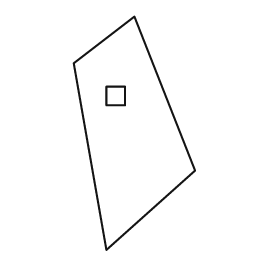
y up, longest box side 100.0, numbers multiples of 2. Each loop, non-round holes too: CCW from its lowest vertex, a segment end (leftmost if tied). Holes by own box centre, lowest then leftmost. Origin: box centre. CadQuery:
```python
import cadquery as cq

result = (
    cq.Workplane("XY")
    .moveTo(-12.0, -50.0)
    .lineTo(26.0, -16.0)
    .lineTo(0.0, 50.0)
    .lineTo(-26.0, 30.0)
    .close()
    .moveTo(-12.0, 12.0)
    .lineTo(-4.0, 12.0)
    .lineTo(-4.0, 20.0)
    .lineTo(-12.0, 20.0)
    .close()
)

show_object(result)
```